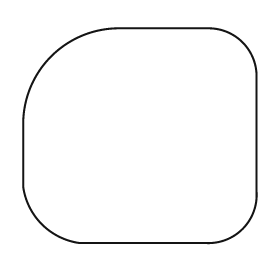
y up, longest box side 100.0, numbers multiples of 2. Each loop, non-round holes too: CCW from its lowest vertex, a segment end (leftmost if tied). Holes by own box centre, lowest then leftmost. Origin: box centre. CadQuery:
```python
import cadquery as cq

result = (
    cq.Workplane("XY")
    .moveTo(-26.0, -46.0)
    .lineTo(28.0, -46.0)
    .threePointArc((44.0, -40.0), (50.0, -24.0))
    .lineTo(50.0, 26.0)
    .threePointArc((44.0, 40.0), (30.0, 46.0))
    .lineTo(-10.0, 46.0)
    .threePointArc((-38.0, 34.0), (-50.0, 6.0))
    .lineTo(-50.0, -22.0)
    .threePointArc((-42.0, -38.0), (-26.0, -46.0))
    .close()
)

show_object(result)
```